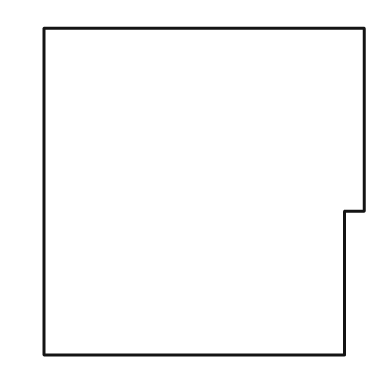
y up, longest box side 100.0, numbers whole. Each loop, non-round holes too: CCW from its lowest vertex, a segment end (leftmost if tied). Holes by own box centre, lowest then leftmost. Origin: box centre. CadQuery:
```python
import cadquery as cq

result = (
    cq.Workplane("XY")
    .moveTo(-49.0, -50.0)
    .lineTo(43.0, -50.0)
    .lineTo(43.0, -6.0)
    .lineTo(49.0, -6.0)
    .lineTo(49.0, 50.0)
    .lineTo(-49.0, 50.0)
    .close()
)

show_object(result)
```